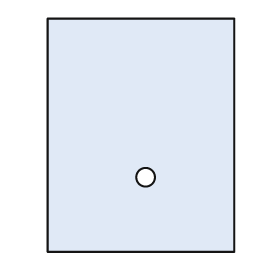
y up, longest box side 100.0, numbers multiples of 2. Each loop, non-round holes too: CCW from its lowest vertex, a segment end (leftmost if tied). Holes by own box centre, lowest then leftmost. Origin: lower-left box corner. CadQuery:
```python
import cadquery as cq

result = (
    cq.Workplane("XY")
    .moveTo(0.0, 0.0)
    .lineTo(80.0, 0.0)
    .lineTo(80.0, 100.0)
    .lineTo(0.0, 100.0)
    .close()
    .moveTo(42.0, 32.0)
    .circle(4.0)
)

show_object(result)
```